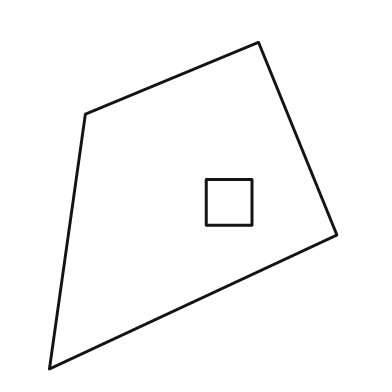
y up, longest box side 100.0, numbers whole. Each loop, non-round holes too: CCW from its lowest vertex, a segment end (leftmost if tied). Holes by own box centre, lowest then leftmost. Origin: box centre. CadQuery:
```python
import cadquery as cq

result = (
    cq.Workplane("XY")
    .moveTo(-44.0, -50.0)
    .lineTo(44.0, -9.0)
    .lineTo(20.0, 50.0)
    .lineTo(-33.0, 28.0)
    .close()
    .moveTo(4.0, -6.0)
    .lineTo(18.0, -6.0)
    .lineTo(18.0, 8.0)
    .lineTo(4.0, 8.0)
    .close()
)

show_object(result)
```